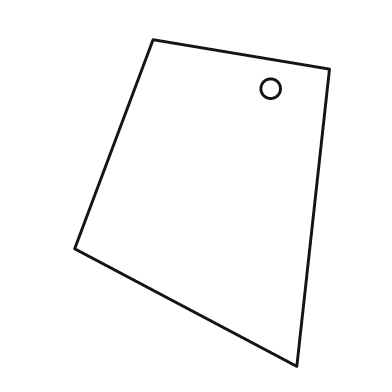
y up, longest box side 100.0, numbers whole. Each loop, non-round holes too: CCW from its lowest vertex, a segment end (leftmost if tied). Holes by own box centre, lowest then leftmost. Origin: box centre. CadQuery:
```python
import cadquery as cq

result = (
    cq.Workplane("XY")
    .moveTo(29.0, -50.0)
    .lineTo(39.0, 41.0)
    .lineTo(-15.0, 50.0)
    .lineTo(-39.0, -14.0)
    .close()
    .moveTo(21.0, 35.0)
    .circle(3.0)
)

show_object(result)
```